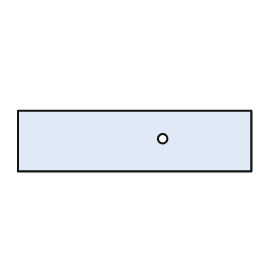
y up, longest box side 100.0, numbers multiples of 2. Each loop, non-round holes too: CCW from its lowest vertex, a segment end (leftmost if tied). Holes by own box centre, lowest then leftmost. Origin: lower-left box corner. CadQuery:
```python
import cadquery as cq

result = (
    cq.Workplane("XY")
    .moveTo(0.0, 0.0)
    .lineTo(100.0, 0.0)
    .lineTo(100.0, 26.0)
    .lineTo(0.0, 26.0)
    .close()
    .moveTo(62.0, 14.0)
    .circle(2.0)
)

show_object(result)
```